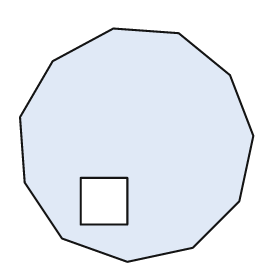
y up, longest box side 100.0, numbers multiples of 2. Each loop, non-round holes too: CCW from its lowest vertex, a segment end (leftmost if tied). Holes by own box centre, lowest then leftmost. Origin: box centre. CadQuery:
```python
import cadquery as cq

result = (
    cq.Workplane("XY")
    .moveTo(-4.0, -50.0)
    .lineTo(24.0, -44.0)
    .lineTo(44.0, -24.0)
    .lineTo(50.0, 4.0)
    .lineTo(40.0, 30.0)
    .lineTo(18.0, 48.0)
    .lineTo(-10.0, 50.0)
    .lineTo(-36.0, 36.0)
    .lineTo(-50.0, 12.0)
    .lineTo(-48.0, -16.0)
    .lineTo(-32.0, -40.0)
    .close()
    .moveTo(-24.0, -34.0)
    .lineTo(-4.0, -34.0)
    .lineTo(-4.0, -14.0)
    .lineTo(-24.0, -14.0)
    .close()
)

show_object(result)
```